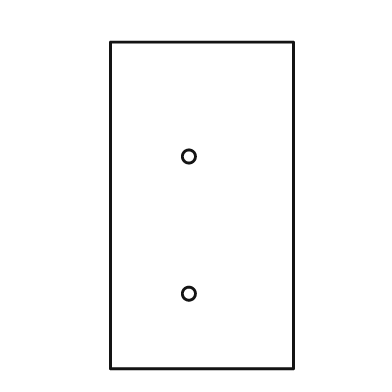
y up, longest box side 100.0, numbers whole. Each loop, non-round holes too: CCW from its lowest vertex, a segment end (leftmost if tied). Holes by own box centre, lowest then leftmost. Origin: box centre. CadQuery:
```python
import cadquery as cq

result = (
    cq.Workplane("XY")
    .moveTo(-28.0, -50.0)
    .lineTo(28.0, -50.0)
    .lineTo(28.0, 50.0)
    .lineTo(-28.0, 50.0)
    .close()
    .moveTo(-4.0, -27.0)
    .circle(2.0)
    .moveTo(-4.0, 15.0)
    .circle(2.0)
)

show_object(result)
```